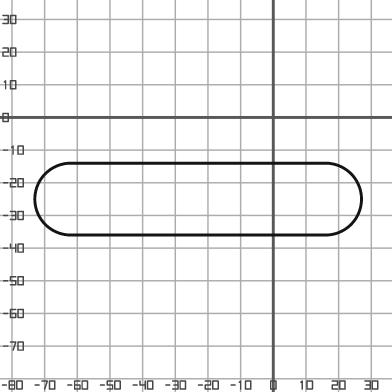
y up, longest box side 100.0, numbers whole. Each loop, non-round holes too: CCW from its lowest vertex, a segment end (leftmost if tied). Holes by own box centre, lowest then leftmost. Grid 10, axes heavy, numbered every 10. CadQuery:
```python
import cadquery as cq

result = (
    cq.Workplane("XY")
    .moveTo(-62.0, -36.0)
    .lineTo(16.0, -36.0)
    .threePointArc((27.0, -25.0), (16.0, -14.0))
    .lineTo(-62.0, -14.0)
    .threePointArc((-73.0, -25.0), (-62.0, -36.0))
    .close()
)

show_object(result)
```